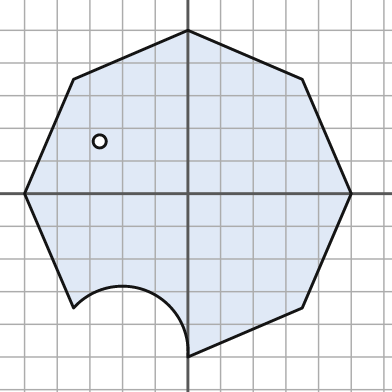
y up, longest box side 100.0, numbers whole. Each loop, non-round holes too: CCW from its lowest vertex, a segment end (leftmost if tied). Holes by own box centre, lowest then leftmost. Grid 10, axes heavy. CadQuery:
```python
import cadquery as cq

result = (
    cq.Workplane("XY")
    .moveTo(0.0, -50.0)
    .lineTo(35.0, -35.0)
    .lineTo(50.0, 0.0)
    .lineTo(35.0, 35.0)
    .lineTo(0.0, 50.0)
    .lineTo(-35.0, 35.0)
    .lineTo(-50.0, 0.0)
    .lineTo(-35.0, -35.0)
    .threePointArc((-12.0, -30.0), (0.0, -50.0))
    .close()
    .moveTo(-27.0, 16.0)
    .circle(2.0)
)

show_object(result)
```